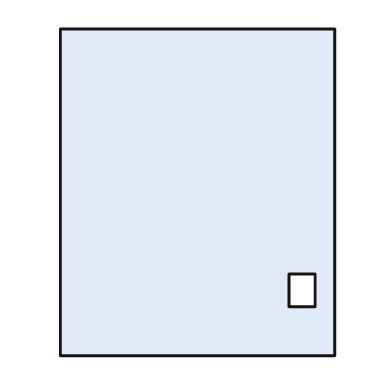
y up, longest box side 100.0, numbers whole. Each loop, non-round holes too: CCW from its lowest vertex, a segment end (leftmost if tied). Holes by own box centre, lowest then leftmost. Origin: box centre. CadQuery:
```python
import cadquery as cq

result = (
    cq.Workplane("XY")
    .moveTo(-42.0, -50.0)
    .lineTo(42.0, -50.0)
    .lineTo(42.0, 50.0)
    .lineTo(-42.0, 50.0)
    .close()
    .moveTo(28.0, -35.0)
    .lineTo(36.0, -35.0)
    .lineTo(36.0, -25.0)
    .lineTo(28.0, -25.0)
    .close()
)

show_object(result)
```